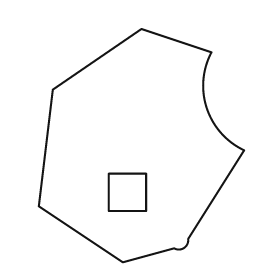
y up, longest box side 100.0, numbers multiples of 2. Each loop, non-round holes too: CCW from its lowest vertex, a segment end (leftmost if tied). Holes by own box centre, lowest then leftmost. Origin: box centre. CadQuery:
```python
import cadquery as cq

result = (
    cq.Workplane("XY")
    .moveTo(-8.0, -50.0)
    .lineTo(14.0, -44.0)
    .threePointArc((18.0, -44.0), (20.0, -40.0))
    .lineTo(44.0, -2.0)
    .threePointArc((28.0, 16.0), (30.0, 40.0))
    .lineTo(0.0, 50.0)
    .lineTo(-38.0, 24.0)
    .lineTo(-44.0, -26.0)
    .close()
    .moveTo(-14.0, -28.0)
    .lineTo(2.0, -28.0)
    .lineTo(2.0, -12.0)
    .lineTo(-14.0, -12.0)
    .close()
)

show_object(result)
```